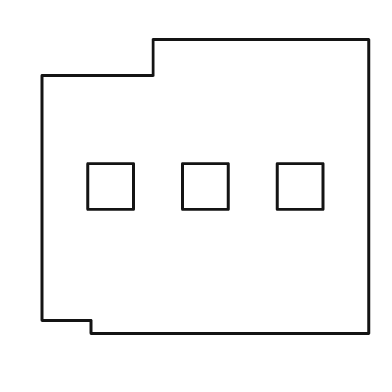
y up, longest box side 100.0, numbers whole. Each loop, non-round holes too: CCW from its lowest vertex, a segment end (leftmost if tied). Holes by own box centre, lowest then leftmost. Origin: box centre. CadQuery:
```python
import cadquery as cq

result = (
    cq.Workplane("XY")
    .moveTo(-35.0, -45.0)
    .lineTo(50.0, -45.0)
    .lineTo(50.0, 45.0)
    .lineTo(-16.0, 45.0)
    .lineTo(-16.0, 34.0)
    .lineTo(-50.0, 34.0)
    .lineTo(-50.0, -41.0)
    .lineTo(-35.0, -41.0)
    .close()
    .moveTo(-36.0, -7.0)
    .lineTo(-22.0, -7.0)
    .lineTo(-22.0, 7.0)
    .lineTo(-36.0, 7.0)
    .close()
    .moveTo(-7.0, -7.0)
    .lineTo(7.0, -7.0)
    .lineTo(7.0, 7.0)
    .lineTo(-7.0, 7.0)
    .close()
    .moveTo(22.0, -7.0)
    .lineTo(36.0, -7.0)
    .lineTo(36.0, 7.0)
    .lineTo(22.0, 7.0)
    .close()
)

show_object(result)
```